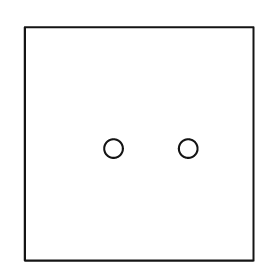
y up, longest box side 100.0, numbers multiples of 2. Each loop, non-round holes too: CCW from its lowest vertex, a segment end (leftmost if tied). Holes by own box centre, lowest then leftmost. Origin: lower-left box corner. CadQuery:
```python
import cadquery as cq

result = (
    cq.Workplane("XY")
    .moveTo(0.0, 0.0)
    .lineTo(98.0, 0.0)
    .lineTo(98.0, 100.0)
    .lineTo(0.0, 100.0)
    .close()
    .moveTo(38.0, 48.0)
    .circle(4.0)
    .moveTo(70.0, 48.0)
    .circle(4.0)
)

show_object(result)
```